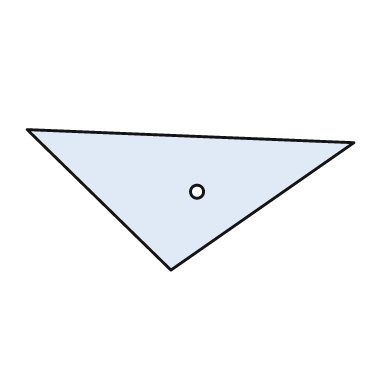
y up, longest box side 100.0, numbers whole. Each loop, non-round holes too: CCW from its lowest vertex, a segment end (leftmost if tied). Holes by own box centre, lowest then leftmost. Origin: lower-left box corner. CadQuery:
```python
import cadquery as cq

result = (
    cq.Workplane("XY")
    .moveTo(44.0, 0.0)
    .lineTo(100.0, 39.0)
    .lineTo(0.0, 43.0)
    .close()
    .moveTo(52.0, 24.0)
    .circle(2.0)
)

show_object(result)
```